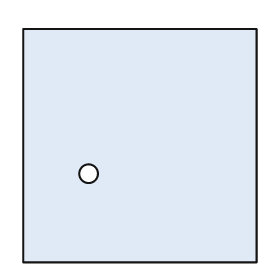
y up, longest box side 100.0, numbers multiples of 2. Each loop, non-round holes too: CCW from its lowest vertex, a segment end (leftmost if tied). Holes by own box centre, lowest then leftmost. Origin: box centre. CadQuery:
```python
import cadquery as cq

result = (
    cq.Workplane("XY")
    .moveTo(-50.0, -50.0)
    .lineTo(50.0, -50.0)
    .lineTo(50.0, 50.0)
    .lineTo(-50.0, 50.0)
    .close()
    .moveTo(-22.0, -12.0)
    .circle(4.0)
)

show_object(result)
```